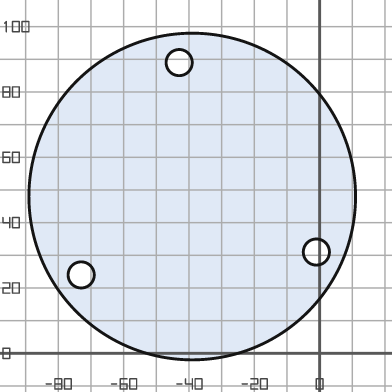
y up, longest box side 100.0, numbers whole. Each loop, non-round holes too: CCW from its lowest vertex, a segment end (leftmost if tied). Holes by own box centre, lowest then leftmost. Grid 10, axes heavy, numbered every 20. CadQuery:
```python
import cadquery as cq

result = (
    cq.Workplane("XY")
    .moveTo(-39.0, 48.0)
    .circle(50.0)
    .moveTo(-73.0, 24.0)
    .circle(4.0)
    .moveTo(-1.0, 31.0)
    .circle(4.0)
    .moveTo(-43.0, 89.0)
    .circle(4.0)
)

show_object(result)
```